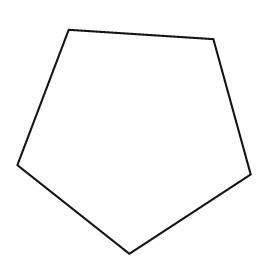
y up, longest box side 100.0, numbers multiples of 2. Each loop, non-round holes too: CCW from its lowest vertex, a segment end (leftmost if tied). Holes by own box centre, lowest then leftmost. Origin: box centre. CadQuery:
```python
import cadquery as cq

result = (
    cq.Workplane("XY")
    .moveTo(-2.0, -48.0)
    .lineTo(50.0, -14.0)
    .lineTo(34.0, 44.0)
    .lineTo(-28.0, 48.0)
    .lineTo(-50.0, -10.0)
    .close()
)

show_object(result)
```